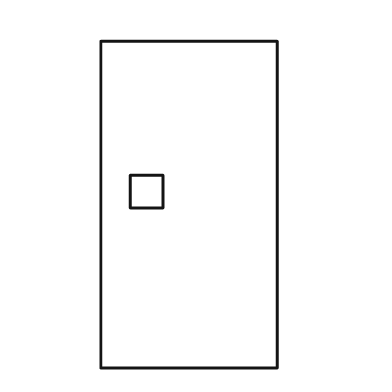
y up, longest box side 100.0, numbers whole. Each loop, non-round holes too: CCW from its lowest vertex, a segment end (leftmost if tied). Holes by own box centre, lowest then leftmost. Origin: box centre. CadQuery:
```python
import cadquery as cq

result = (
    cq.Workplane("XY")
    .moveTo(-27.0, -50.0)
    .lineTo(27.0, -50.0)
    .lineTo(27.0, 50.0)
    .lineTo(-27.0, 50.0)
    .close()
    .moveTo(-18.0, -1.0)
    .lineTo(-8.0, -1.0)
    .lineTo(-8.0, 9.0)
    .lineTo(-18.0, 9.0)
    .close()
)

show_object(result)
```